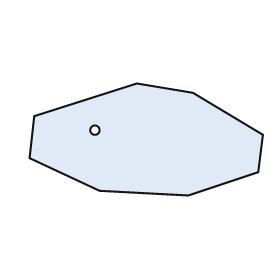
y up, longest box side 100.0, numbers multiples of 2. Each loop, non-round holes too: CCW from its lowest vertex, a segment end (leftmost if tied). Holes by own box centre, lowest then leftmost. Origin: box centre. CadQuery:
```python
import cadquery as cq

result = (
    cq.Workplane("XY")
    .moveTo(18.0, -24.0)
    .lineTo(48.0, -14.0)
    .lineTo(50.0, 2.0)
    .lineTo(20.0, 20.0)
    .lineTo(-4.0, 24.0)
    .lineTo(-48.0, 10.0)
    .lineTo(-50.0, -8.0)
    .lineTo(-20.0, -22.0)
    .close()
    .moveTo(-22.0, 4.0)
    .circle(2.0)
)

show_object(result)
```